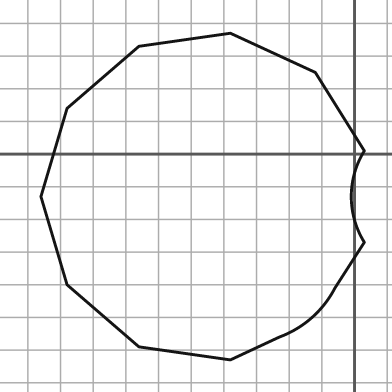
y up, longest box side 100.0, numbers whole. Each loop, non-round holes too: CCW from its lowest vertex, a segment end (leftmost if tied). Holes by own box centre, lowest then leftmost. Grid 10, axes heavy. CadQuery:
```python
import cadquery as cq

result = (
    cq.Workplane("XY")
    .moveTo(-38.0, -63.0)
    .lineTo(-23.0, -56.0)
    .threePointArc((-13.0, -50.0), (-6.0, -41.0))
    .lineTo(3.0, -27.0)
    .threePointArc((-1.0, -13.0), (3.0, 1.0))
    .lineTo(-12.0, 25.0)
    .lineTo(-38.0, 37.0)
    .lineTo(-66.0, 33.0)
    .lineTo(-88.0, 14.0)
    .lineTo(-96.0, -13.0)
    .lineTo(-88.0, -40.0)
    .lineTo(-66.0, -59.0)
    .close()
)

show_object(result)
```